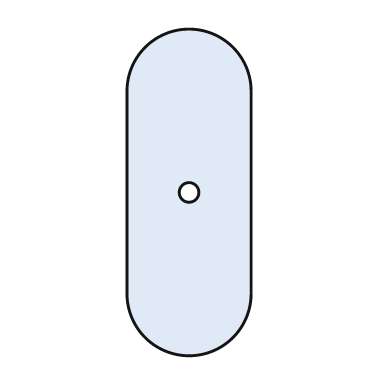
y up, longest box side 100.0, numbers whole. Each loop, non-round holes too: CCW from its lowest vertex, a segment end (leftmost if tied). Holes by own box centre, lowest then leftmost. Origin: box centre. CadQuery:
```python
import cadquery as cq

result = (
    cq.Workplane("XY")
    .moveTo(-19.0, -31.0)
    .threePointArc((0.0, -50.0), (19.0, -31.0))
    .lineTo(19.0, 31.0)
    .threePointArc((0.0, 50.0), (-19.0, 31.0))
    .close()
    .moveTo(0.0, 0.0)
    .circle(3.0)
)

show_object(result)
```